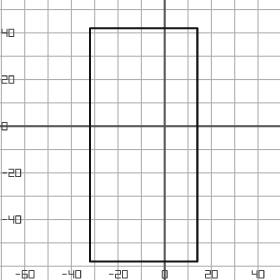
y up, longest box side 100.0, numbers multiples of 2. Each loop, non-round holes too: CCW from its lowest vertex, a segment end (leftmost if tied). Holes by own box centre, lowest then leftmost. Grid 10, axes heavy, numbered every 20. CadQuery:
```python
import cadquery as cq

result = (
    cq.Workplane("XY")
    .moveTo(-32.0, -58.0)
    .lineTo(14.0, -58.0)
    .lineTo(14.0, 42.0)
    .lineTo(-32.0, 42.0)
    .close()
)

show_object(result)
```